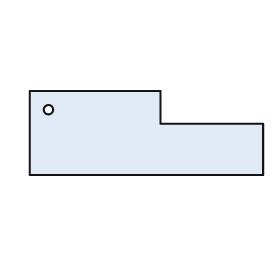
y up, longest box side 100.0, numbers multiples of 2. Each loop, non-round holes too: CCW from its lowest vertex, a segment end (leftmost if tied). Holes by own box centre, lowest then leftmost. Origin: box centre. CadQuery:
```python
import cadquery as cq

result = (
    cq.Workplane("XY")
    .moveTo(-50.0, -18.0)
    .lineTo(50.0, -18.0)
    .lineTo(50.0, 4.0)
    .lineTo(6.0, 4.0)
    .lineTo(6.0, 18.0)
    .lineTo(-50.0, 18.0)
    .close()
    .moveTo(-42.0, 10.0)
    .circle(2.0)
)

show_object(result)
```